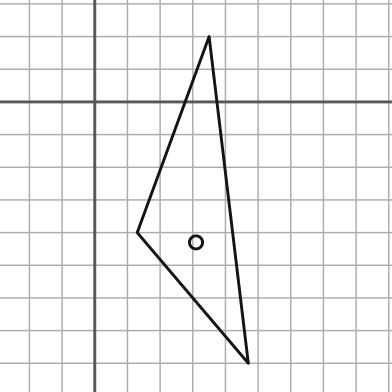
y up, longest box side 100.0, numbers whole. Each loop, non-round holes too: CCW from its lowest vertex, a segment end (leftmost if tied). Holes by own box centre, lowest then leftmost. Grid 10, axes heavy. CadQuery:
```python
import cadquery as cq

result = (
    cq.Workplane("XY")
    .moveTo(47.0, -80.0)
    .lineTo(35.0, 20.0)
    .lineTo(13.0, -40.0)
    .close()
    .moveTo(31.0, -43.0)
    .circle(2.0)
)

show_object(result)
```